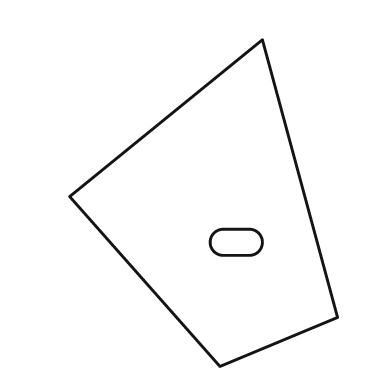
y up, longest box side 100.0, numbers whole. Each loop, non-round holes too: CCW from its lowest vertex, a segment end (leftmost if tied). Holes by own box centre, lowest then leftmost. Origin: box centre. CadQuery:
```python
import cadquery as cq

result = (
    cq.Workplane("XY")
    .moveTo(5.0, -50.0)
    .lineTo(41.0, -35.0)
    .lineTo(18.0, 50.0)
    .lineTo(-41.0, 2.0)
    .close()
    .moveTo(6.0, -16.0)
    .lineTo(14.0, -16.0)
    .threePointArc((18.0, -12.0), (14.0, -8.0))
    .lineTo(6.0, -8.0)
    .threePointArc((2.0, -12.0), (6.0, -16.0))
    .close()
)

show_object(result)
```